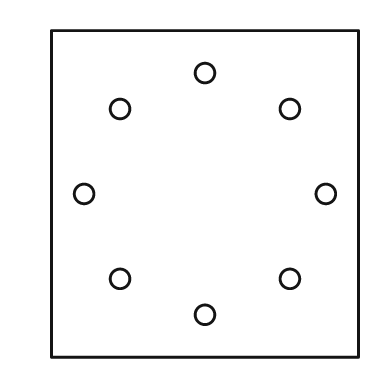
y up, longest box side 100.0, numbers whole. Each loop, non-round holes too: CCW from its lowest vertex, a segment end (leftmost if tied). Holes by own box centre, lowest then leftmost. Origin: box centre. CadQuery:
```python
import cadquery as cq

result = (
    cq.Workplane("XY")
    .moveTo(-47.0, -50.0)
    .lineTo(47.0, -50.0)
    .lineTo(47.0, 50.0)
    .lineTo(-47.0, 50.0)
    .close()
    .moveTo(0.0, -37.0)
    .circle(3.0)
    .moveTo(-26.0, -26.0)
    .circle(3.0)
    .moveTo(26.0, -26.0)
    .circle(3.0)
    .moveTo(-37.0, 0.0)
    .circle(3.0)
    .moveTo(37.0, 0.0)
    .circle(3.0)
    .moveTo(-26.0, 26.0)
    .circle(3.0)
    .moveTo(26.0, 26.0)
    .circle(3.0)
    .moveTo(0.0, 37.0)
    .circle(3.0)
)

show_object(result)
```